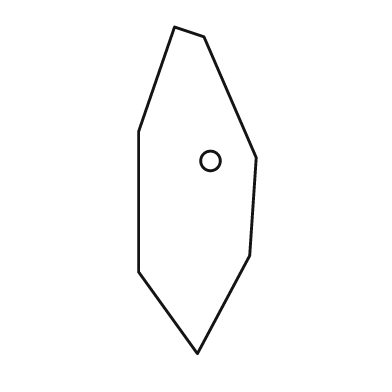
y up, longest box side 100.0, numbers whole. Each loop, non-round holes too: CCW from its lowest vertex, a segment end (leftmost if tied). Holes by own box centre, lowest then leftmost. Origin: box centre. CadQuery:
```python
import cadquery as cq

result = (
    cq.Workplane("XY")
    .moveTo(0.0, -50.0)
    .lineTo(16.0, -20.0)
    .lineTo(18.0, 10.0)
    .lineTo(2.0, 47.0)
    .lineTo(-7.0, 50.0)
    .lineTo(-18.0, 18.0)
    .lineTo(-18.0, -25.0)
    .close()
    .moveTo(4.0, 9.0)
    .circle(3.0)
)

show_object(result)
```